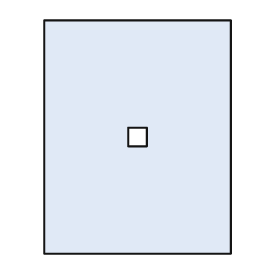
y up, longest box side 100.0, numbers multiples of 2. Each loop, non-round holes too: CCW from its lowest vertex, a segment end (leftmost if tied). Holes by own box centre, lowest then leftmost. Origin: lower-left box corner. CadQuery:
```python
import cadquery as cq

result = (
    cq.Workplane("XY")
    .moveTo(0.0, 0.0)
    .lineTo(80.0, 0.0)
    .lineTo(80.0, 100.0)
    .lineTo(0.0, 100.0)
    .close()
    .moveTo(36.0, 46.0)
    .lineTo(44.0, 46.0)
    .lineTo(44.0, 54.0)
    .lineTo(36.0, 54.0)
    .close()
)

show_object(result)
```